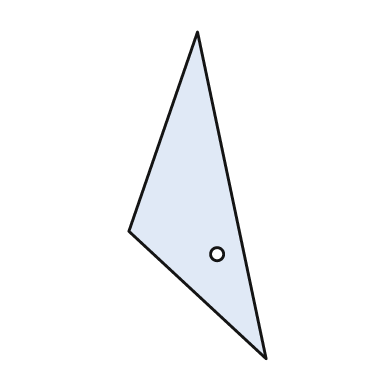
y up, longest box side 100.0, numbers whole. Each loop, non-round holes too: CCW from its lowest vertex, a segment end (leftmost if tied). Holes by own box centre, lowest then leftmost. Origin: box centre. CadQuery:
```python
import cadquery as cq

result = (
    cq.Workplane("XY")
    .moveTo(21.0, -50.0)
    .lineTo(0.0, 50.0)
    .lineTo(-21.0, -11.0)
    .close()
    .moveTo(6.0, -18.0)
    .circle(2.0)
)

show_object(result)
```